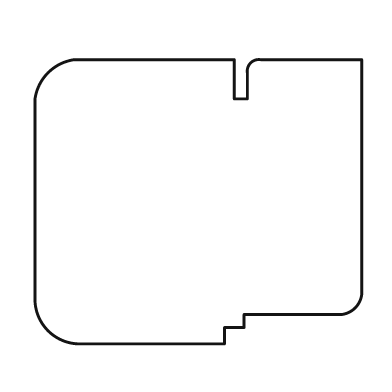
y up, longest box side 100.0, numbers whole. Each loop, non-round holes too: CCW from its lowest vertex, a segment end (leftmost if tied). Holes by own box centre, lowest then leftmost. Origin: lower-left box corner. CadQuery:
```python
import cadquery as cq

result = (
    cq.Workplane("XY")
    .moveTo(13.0, 0.0)
    .lineTo(58.0, 0.0)
    .lineTo(58.0, 5.0)
    .lineTo(64.0, 5.0)
    .lineTo(64.0, 9.0)
    .lineTo(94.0, 9.0)
    .threePointArc((98.0, 11.0), (100.0, 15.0))
    .lineTo(100.0, 87.0)
    .lineTo(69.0, 87.0)
    .threePointArc((66.0, 86.0), (65.0, 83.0))
    .lineTo(65.0, 75.0)
    .lineTo(61.0, 75.0)
    .lineTo(61.0, 87.0)
    .lineTo(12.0, 87.0)
    .threePointArc((4.0, 83.0), (0.0, 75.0))
    .lineTo(0.0, 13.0)
    .threePointArc((4.0, 4.0), (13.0, 0.0))
    .close()
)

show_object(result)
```